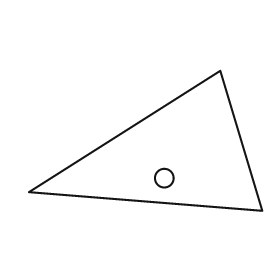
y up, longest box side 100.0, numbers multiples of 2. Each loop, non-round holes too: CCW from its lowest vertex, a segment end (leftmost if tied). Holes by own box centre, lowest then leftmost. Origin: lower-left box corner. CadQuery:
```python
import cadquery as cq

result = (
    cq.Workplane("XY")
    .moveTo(100.0, 0.0)
    .lineTo(82.0, 60.0)
    .lineTo(0.0, 8.0)
    .close()
    .moveTo(58.0, 14.0)
    .circle(4.0)
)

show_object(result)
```